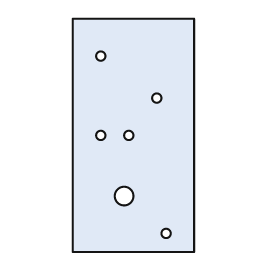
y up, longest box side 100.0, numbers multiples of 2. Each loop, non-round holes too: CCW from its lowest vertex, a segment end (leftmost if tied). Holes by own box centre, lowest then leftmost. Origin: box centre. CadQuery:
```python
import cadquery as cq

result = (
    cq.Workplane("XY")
    .moveTo(-26.0, -50.0)
    .lineTo(26.0, -50.0)
    .lineTo(26.0, 50.0)
    .lineTo(-26.0, 50.0)
    .close()
    .moveTo(14.0, -42.0)
    .circle(2.0)
    .moveTo(-4.0, -26.0)
    .circle(4.0)
    .moveTo(-14.0, 0.0)
    .circle(2.0)
    .moveTo(-2.0, 0.0)
    .circle(2.0)
    .moveTo(10.0, 16.0)
    .circle(2.0)
    .moveTo(-14.0, 34.0)
    .circle(2.0)
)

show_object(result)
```